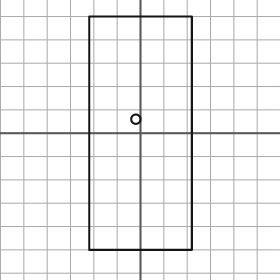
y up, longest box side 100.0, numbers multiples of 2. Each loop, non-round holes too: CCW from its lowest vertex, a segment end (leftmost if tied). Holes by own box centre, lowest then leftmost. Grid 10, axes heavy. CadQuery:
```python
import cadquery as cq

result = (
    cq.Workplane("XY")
    .moveTo(-22.0, -50.0)
    .lineTo(22.0, -50.0)
    .lineTo(22.0, 50.0)
    .lineTo(-22.0, 50.0)
    .close()
    .moveTo(-2.0, 6.0)
    .circle(2.0)
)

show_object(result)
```